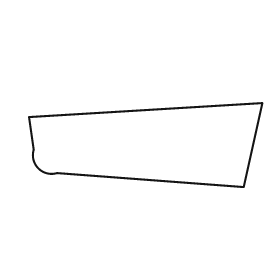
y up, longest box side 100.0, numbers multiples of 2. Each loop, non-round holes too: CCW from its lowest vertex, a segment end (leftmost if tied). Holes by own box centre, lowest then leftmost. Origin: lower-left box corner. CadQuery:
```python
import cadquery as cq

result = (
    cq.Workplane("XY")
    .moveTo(92.0, 0.0)
    .lineTo(100.0, 36.0)
    .lineTo(0.0, 30.0)
    .lineTo(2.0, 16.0)
    .threePointArc((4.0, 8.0), (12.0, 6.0))
    .close()
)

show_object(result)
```